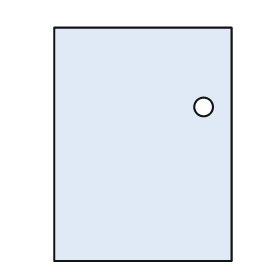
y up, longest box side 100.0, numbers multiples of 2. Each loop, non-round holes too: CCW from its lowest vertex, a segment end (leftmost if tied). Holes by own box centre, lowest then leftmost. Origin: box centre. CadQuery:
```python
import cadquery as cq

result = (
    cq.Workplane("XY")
    .moveTo(-38.0, -50.0)
    .lineTo(38.0, -50.0)
    .lineTo(38.0, 50.0)
    .lineTo(-38.0, 50.0)
    .close()
    .moveTo(26.0, 16.0)
    .circle(4.0)
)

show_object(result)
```